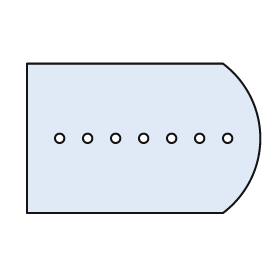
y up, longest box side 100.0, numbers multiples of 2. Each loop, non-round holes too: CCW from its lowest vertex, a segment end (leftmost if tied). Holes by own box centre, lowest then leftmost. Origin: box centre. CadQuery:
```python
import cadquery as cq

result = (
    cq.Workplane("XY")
    .moveTo(-50.0, -32.0)
    .lineTo(34.0, -32.0)
    .threePointArc((50.0, 0.0), (34.0, 32.0))
    .lineTo(-50.0, 32.0)
    .close()
    .moveTo(-36.0, 0.0)
    .circle(2.0)
    .moveTo(-24.0, 0.0)
    .circle(2.0)
    .moveTo(-12.0, 0.0)
    .circle(2.0)
    .moveTo(0.0, 0.0)
    .circle(2.0)
    .moveTo(12.0, 0.0)
    .circle(2.0)
    .moveTo(24.0, 0.0)
    .circle(2.0)
    .moveTo(36.0, 0.0)
    .circle(2.0)
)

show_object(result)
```